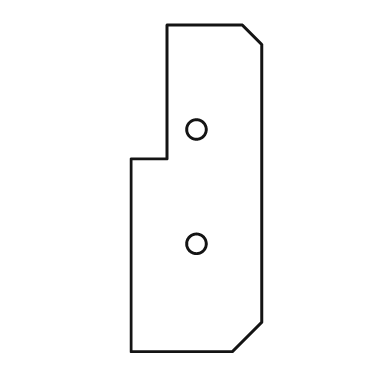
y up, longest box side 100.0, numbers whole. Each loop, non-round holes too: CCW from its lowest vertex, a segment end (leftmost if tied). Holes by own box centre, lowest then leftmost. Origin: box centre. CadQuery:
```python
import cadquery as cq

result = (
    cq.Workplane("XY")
    .moveTo(-20.0, -50.0)
    .lineTo(11.0, -50.0)
    .lineTo(20.0, -41.0)
    .lineTo(20.0, 44.0)
    .lineTo(14.0, 50.0)
    .lineTo(-9.0, 50.0)
    .lineTo(-9.0, 9.0)
    .lineTo(-20.0, 9.0)
    .close()
    .moveTo(0.0, -17.0)
    .circle(3.0)
    .moveTo(0.0, 18.0)
    .circle(3.0)
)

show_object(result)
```